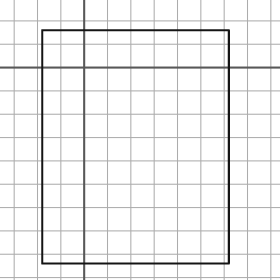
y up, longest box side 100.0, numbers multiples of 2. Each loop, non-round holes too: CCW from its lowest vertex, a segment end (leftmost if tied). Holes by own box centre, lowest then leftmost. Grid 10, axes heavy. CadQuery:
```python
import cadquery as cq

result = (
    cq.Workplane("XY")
    .moveTo(-18.0, -84.0)
    .lineTo(62.0, -84.0)
    .lineTo(62.0, 16.0)
    .lineTo(-18.0, 16.0)
    .close()
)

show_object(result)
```